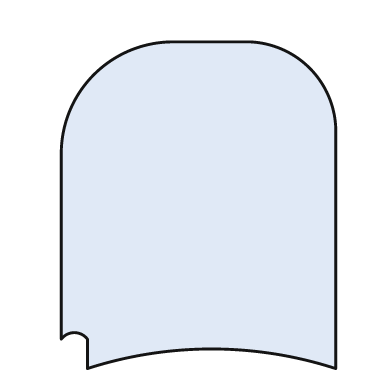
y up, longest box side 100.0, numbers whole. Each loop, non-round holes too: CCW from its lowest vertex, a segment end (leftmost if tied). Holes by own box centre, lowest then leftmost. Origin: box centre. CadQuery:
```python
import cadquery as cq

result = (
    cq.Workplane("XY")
    .moveTo(-34.0, -50.0)
    .threePointArc((4.0, -44.0), (42.0, -50.0))
    .lineTo(42.0, 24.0)
    .threePointArc((34.0, 42.0), (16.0, 50.0))
    .lineTo(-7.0, 50.0)
    .threePointArc((-32.0, 40.0), (-42.0, 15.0))
    .lineTo(-42.0, -41.0)
    .threePointArc((-38.0, -39.0), (-34.0, -41.0))
    .close()
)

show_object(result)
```